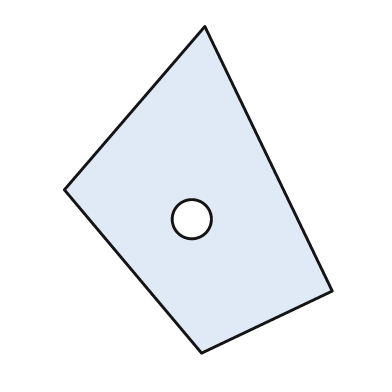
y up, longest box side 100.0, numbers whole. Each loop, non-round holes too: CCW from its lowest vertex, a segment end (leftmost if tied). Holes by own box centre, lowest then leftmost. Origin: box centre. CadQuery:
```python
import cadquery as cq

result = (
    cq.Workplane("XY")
    .moveTo(1.0, -50.0)
    .lineTo(41.0, -31.0)
    .lineTo(2.0, 50.0)
    .lineTo(-41.0, 0.0)
    .close()
    .moveTo(-2.0, -9.0)
    .circle(6.0)
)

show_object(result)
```